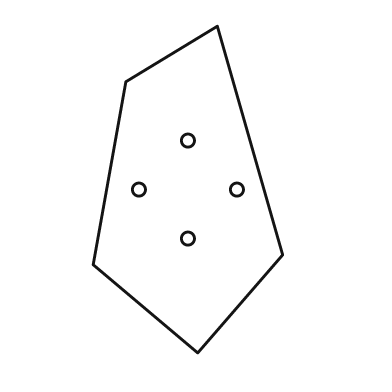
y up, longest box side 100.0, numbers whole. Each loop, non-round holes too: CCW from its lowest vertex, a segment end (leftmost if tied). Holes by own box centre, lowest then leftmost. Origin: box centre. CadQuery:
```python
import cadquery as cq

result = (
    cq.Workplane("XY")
    .moveTo(3.0, -50.0)
    .lineTo(29.0, -20.0)
    .lineTo(9.0, 50.0)
    .lineTo(-19.0, 33.0)
    .lineTo(-29.0, -23.0)
    .close()
    .moveTo(0.0, -15.0)
    .circle(2.0)
    .moveTo(-15.0, 0.0)
    .circle(2.0)
    .moveTo(15.0, 0.0)
    .circle(2.0)
    .moveTo(0.0, 15.0)
    .circle(2.0)
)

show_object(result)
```